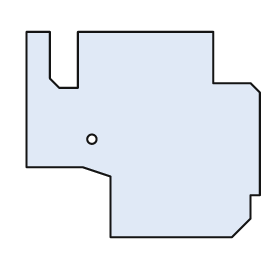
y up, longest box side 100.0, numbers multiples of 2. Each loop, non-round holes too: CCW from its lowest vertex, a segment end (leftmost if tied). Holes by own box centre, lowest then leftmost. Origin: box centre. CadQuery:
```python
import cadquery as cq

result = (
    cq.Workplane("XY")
    .moveTo(-14.0, -44.0)
    .lineTo(38.0, -44.0)
    .lineTo(46.0, -36.0)
    .lineTo(46.0, -26.0)
    .lineTo(50.0, -26.0)
    .lineTo(50.0, 18.0)
    .lineTo(46.0, 22.0)
    .lineTo(30.0, 22.0)
    .lineTo(30.0, 44.0)
    .lineTo(-28.0, 44.0)
    .lineTo(-28.0, 20.0)
    .lineTo(-36.0, 20.0)
    .lineTo(-40.0, 24.0)
    .lineTo(-40.0, 44.0)
    .lineTo(-50.0, 44.0)
    .lineTo(-50.0, -14.0)
    .lineTo(-26.0, -14.0)
    .lineTo(-14.0, -18.0)
    .close()
    .moveTo(-22.0, -2.0)
    .circle(2.0)
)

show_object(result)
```